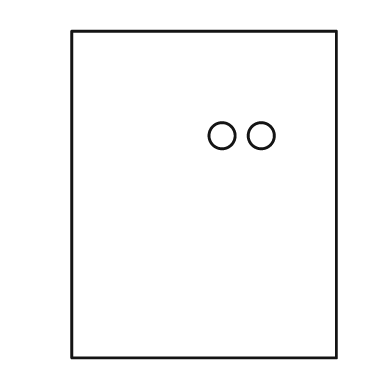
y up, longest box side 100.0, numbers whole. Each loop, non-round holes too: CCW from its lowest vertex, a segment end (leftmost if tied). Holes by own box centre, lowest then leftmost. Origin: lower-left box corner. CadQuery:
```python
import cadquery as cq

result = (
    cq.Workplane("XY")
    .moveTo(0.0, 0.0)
    .lineTo(81.0, 0.0)
    .lineTo(81.0, 100.0)
    .lineTo(0.0, 100.0)
    .close()
    .moveTo(46.0, 68.0)
    .circle(4.0)
    .moveTo(58.0, 68.0)
    .circle(4.0)
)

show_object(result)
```